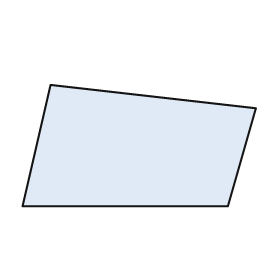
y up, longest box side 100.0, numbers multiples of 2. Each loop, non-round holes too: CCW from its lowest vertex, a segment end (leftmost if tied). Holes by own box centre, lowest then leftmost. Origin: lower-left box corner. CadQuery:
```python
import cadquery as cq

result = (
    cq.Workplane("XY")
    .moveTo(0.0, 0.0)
    .lineTo(88.0, 0.0)
    .lineTo(100.0, 42.0)
    .lineTo(12.0, 52.0)
    .close()
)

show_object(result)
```